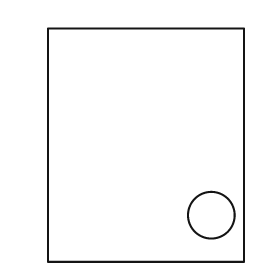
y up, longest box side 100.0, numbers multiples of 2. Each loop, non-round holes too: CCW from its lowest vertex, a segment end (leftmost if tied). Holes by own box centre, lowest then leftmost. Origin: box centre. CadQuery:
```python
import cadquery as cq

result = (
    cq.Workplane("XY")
    .moveTo(-42.0, -50.0)
    .lineTo(42.0, -50.0)
    .lineTo(42.0, 50.0)
    .lineTo(-42.0, 50.0)
    .close()
    .moveTo(28.0, -30.0)
    .circle(10.0)
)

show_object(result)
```